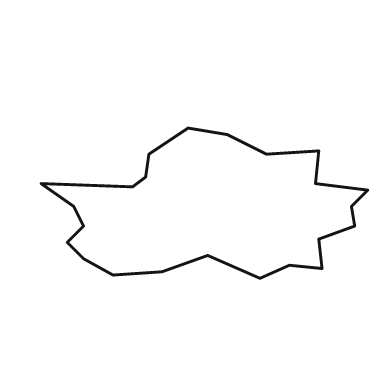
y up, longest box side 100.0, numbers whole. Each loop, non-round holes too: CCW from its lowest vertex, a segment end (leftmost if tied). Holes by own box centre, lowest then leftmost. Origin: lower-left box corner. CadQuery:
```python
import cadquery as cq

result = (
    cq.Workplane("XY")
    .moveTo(67.0, 0.0)
    .lineTo(76.0, 4.0)
    .lineTo(86.0, 3.0)
    .lineTo(85.0, 12.0)
    .lineTo(96.0, 16.0)
    .lineTo(95.0, 22.0)
    .lineTo(100.0, 27.0)
    .lineTo(84.0, 29.0)
    .lineTo(85.0, 39.0)
    .lineTo(69.0, 38.0)
    .lineTo(57.0, 44.0)
    .lineTo(45.0, 46.0)
    .lineTo(33.0, 38.0)
    .lineTo(32.0, 31.0)
    .lineTo(28.0, 28.0)
    .lineTo(0.0, 29.0)
    .lineTo(10.0, 22.0)
    .lineTo(13.0, 16.0)
    .lineTo(8.0, 11.0)
    .lineTo(13.0, 6.0)
    .lineTo(22.0, 1.0)
    .lineTo(37.0, 2.0)
    .lineTo(51.0, 7.0)
    .close()
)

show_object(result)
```